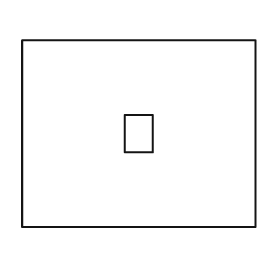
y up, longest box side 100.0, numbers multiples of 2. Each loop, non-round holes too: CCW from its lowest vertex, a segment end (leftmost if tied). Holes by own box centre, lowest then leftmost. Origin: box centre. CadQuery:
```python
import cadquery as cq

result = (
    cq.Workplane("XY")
    .moveTo(-50.0, -40.0)
    .lineTo(50.0, -40.0)
    .lineTo(50.0, 40.0)
    .lineTo(-50.0, 40.0)
    .close()
    .moveTo(-6.0, -8.0)
    .lineTo(6.0, -8.0)
    .lineTo(6.0, 8.0)
    .lineTo(-6.0, 8.0)
    .close()
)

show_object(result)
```